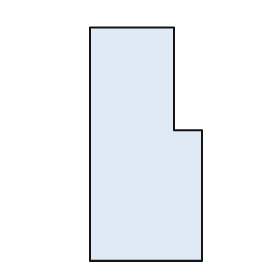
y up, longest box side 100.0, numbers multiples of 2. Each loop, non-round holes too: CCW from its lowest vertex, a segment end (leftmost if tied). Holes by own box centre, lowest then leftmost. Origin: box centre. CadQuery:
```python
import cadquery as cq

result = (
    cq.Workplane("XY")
    .moveTo(-24.0, -50.0)
    .lineTo(24.0, -50.0)
    .lineTo(24.0, 6.0)
    .lineTo(12.0, 6.0)
    .lineTo(12.0, 50.0)
    .lineTo(-24.0, 50.0)
    .close()
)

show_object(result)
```